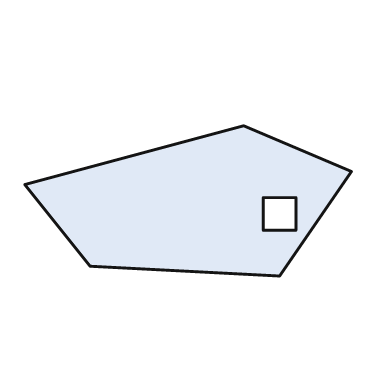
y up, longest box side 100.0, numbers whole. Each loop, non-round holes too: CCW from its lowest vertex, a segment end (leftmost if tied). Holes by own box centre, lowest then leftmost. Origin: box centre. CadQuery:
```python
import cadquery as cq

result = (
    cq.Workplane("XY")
    .moveTo(28.0, -23.0)
    .lineTo(50.0, 9.0)
    .lineTo(17.0, 23.0)
    .lineTo(-50.0, 5.0)
    .lineTo(-30.0, -20.0)
    .close()
    .moveTo(23.0, -9.0)
    .lineTo(33.0, -9.0)
    .lineTo(33.0, 1.0)
    .lineTo(23.0, 1.0)
    .close()
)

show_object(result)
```